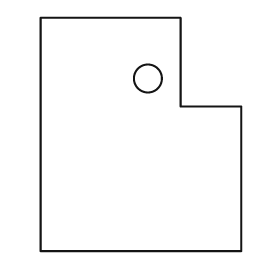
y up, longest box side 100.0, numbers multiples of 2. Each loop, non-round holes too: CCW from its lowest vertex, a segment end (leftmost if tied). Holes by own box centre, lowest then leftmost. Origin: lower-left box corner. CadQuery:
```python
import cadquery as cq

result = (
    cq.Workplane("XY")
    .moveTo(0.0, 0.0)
    .lineTo(86.0, 0.0)
    .lineTo(86.0, 62.0)
    .lineTo(60.0, 62.0)
    .lineTo(60.0, 100.0)
    .lineTo(0.0, 100.0)
    .close()
    .moveTo(46.0, 74.0)
    .circle(6.0)
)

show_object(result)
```